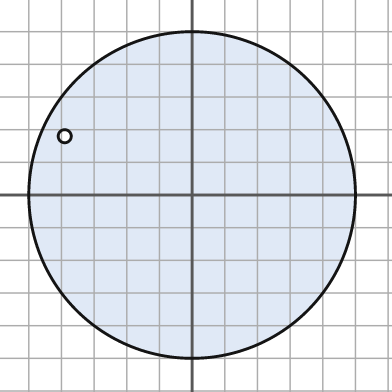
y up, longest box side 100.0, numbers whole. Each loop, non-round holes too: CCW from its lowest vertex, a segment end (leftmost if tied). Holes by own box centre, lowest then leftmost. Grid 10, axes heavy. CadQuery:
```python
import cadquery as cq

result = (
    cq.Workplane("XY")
    .moveTo(0.0, 0.0)
    .circle(50.0)
    .moveTo(-39.0, 18.0)
    .circle(2.0)
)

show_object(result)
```